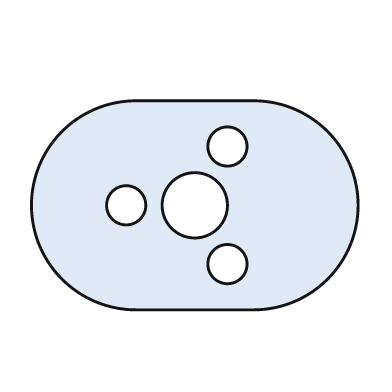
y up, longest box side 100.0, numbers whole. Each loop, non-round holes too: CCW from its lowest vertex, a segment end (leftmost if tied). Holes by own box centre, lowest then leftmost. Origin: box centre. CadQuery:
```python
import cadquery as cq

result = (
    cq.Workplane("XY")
    .moveTo(-18.0, -32.0)
    .lineTo(18.0, -32.0)
    .threePointArc((50.0, 0.0), (18.0, 32.0))
    .lineTo(-18.0, 32.0)
    .threePointArc((-50.0, 0.0), (-18.0, -32.0))
    .close()
    .moveTo(10.0, -18.0)
    .circle(6.0)
    .moveTo(-21.0, 0.0)
    .circle(6.0)
    .moveTo(0.0, 0.0)
    .circle(10.0)
    .moveTo(10.0, 18.0)
    .circle(6.0)
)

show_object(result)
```